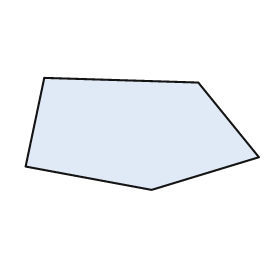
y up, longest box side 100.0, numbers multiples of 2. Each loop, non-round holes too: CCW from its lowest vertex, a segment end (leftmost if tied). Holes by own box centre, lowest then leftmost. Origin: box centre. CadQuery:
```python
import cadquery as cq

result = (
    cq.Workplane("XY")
    .moveTo(4.0, -24.0)
    .lineTo(50.0, -10.0)
    .lineTo(24.0, 22.0)
    .lineTo(-42.0, 24.0)
    .lineTo(-50.0, -14.0)
    .close()
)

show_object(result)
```